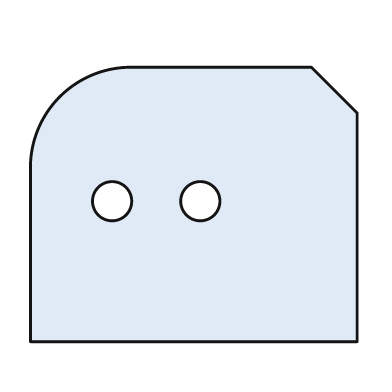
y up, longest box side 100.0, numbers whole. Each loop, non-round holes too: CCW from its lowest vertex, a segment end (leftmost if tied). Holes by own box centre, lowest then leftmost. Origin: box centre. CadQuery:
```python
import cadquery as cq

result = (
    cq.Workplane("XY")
    .moveTo(-50.0, -42.0)
    .lineTo(50.0, -42.0)
    .lineTo(50.0, 28.0)
    .lineTo(36.0, 42.0)
    .lineTo(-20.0, 42.0)
    .threePointArc((-41.0, 33.0), (-50.0, 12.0))
    .close()
    .moveTo(-25.0, 1.0)
    .circle(6.0)
    .moveTo(2.0, 1.0)
    .circle(6.0)
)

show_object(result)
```